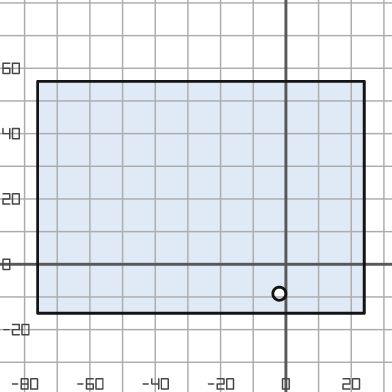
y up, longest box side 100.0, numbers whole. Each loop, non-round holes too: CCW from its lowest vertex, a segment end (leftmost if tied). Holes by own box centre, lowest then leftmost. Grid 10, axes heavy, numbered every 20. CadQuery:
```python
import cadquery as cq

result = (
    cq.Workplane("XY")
    .moveTo(-76.0, -15.0)
    .lineTo(24.0, -15.0)
    .lineTo(24.0, 56.0)
    .lineTo(-76.0, 56.0)
    .close()
    .moveTo(-2.0, -9.0)
    .circle(2.0)
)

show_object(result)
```